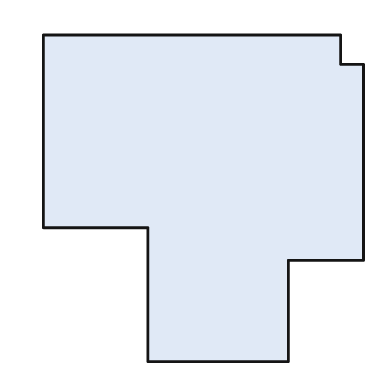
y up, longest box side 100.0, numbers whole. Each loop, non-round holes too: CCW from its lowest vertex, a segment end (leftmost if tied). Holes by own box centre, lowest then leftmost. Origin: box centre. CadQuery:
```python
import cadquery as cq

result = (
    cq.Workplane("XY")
    .moveTo(-17.0, -50.0)
    .lineTo(26.0, -50.0)
    .lineTo(26.0, -19.0)
    .lineTo(49.0, -19.0)
    .lineTo(49.0, 41.0)
    .lineTo(42.0, 41.0)
    .lineTo(42.0, 50.0)
    .lineTo(-49.0, 50.0)
    .lineTo(-49.0, -9.0)
    .lineTo(-17.0, -9.0)
    .close()
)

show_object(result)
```